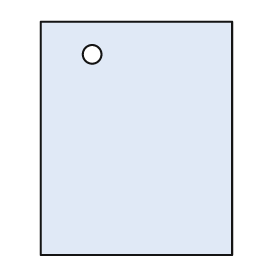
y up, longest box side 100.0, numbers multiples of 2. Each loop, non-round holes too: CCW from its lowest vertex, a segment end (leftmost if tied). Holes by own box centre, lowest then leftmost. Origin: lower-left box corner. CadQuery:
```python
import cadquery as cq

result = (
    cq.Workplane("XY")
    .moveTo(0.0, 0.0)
    .lineTo(82.0, 0.0)
    .lineTo(82.0, 100.0)
    .lineTo(0.0, 100.0)
    .close()
    .moveTo(22.0, 86.0)
    .circle(4.0)
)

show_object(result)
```